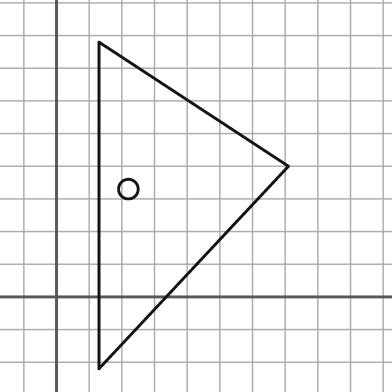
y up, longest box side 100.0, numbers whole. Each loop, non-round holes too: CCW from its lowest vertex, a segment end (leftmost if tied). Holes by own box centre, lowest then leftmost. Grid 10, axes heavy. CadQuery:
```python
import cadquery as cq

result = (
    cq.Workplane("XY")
    .moveTo(13.0, -22.0)
    .lineTo(71.0, 40.0)
    .lineTo(13.0, 78.0)
    .close()
    .moveTo(22.0, 33.0)
    .circle(3.0)
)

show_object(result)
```